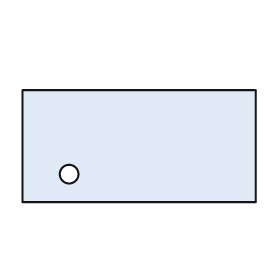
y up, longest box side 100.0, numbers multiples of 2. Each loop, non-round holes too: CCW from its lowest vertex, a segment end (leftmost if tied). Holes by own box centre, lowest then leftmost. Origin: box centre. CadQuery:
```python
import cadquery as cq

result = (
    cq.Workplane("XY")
    .moveTo(-50.0, -24.0)
    .lineTo(50.0, -24.0)
    .lineTo(50.0, 24.0)
    .lineTo(-50.0, 24.0)
    .close()
    .moveTo(-30.0, -12.0)
    .circle(4.0)
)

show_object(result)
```